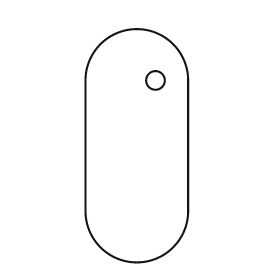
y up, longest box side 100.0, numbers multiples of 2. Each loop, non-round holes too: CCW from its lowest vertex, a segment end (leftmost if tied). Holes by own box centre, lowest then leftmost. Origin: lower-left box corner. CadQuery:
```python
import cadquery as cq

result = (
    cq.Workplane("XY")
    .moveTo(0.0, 22.0)
    .threePointArc((22.0, 0.0), (44.0, 22.0))
    .lineTo(44.0, 78.0)
    .threePointArc((22.0, 100.0), (0.0, 78.0))
    .close()
    .moveTo(30.0, 78.0)
    .circle(4.0)
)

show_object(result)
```